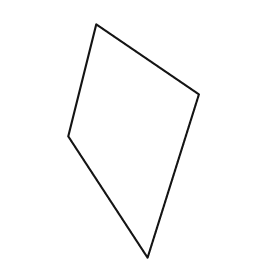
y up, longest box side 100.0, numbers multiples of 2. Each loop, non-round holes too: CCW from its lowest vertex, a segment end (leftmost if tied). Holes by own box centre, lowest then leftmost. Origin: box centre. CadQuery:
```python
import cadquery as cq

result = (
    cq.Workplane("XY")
    .moveTo(6.0, -50.0)
    .lineTo(28.0, 20.0)
    .lineTo(-16.0, 50.0)
    .lineTo(-28.0, 2.0)
    .close()
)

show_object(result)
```